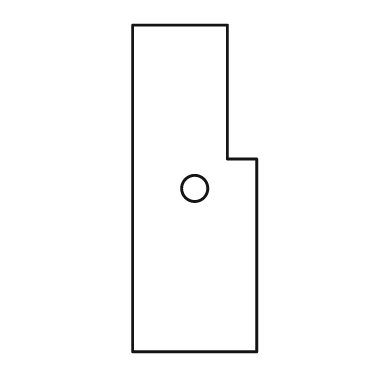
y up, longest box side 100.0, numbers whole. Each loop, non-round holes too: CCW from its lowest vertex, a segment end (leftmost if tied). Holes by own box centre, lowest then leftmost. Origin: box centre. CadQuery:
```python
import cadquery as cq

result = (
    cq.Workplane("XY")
    .moveTo(-19.0, -50.0)
    .lineTo(19.0, -50.0)
    .lineTo(19.0, 9.0)
    .lineTo(10.0, 9.0)
    .lineTo(10.0, 50.0)
    .lineTo(-19.0, 50.0)
    .close()
    .moveTo(0.0, 0.0)
    .circle(4.0)
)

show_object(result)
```